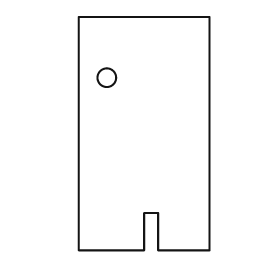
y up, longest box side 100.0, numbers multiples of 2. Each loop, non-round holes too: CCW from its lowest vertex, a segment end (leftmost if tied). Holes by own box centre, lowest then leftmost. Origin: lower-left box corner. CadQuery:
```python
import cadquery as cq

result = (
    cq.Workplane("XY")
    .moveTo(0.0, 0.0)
    .lineTo(28.0, 0.0)
    .lineTo(28.0, 16.0)
    .lineTo(34.0, 16.0)
    .lineTo(34.0, 0.0)
    .lineTo(56.0, 0.0)
    .lineTo(56.0, 100.0)
    .lineTo(0.0, 100.0)
    .close()
    .moveTo(12.0, 74.0)
    .circle(4.0)
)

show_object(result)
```